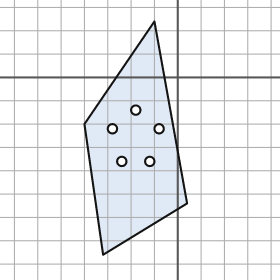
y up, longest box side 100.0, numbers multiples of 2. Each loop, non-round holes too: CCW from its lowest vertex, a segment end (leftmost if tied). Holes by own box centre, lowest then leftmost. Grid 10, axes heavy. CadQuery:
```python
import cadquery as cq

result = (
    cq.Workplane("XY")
    .moveTo(-32.0, -76.0)
    .lineTo(4.0, -54.0)
    .lineTo(-10.0, 24.0)
    .lineTo(-40.0, -20.0)
    .close()
    .moveTo(-24.0, -36.0)
    .circle(2.0)
    .moveTo(-12.0, -36.0)
    .circle(2.0)
    .moveTo(-28.0, -22.0)
    .circle(2.0)
    .moveTo(-8.0, -22.0)
    .circle(2.0)
    .moveTo(-18.0, -14.0)
    .circle(2.0)
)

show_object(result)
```